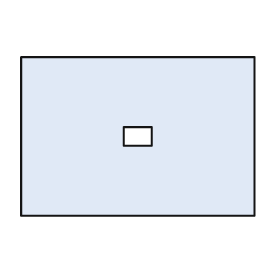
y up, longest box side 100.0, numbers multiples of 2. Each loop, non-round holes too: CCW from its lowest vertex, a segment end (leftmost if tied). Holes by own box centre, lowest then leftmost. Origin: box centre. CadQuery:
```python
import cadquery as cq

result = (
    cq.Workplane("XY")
    .moveTo(-50.0, -34.0)
    .lineTo(50.0, -34.0)
    .lineTo(50.0, 34.0)
    .lineTo(-50.0, 34.0)
    .close()
    .moveTo(-6.0, -4.0)
    .lineTo(6.0, -4.0)
    .lineTo(6.0, 4.0)
    .lineTo(-6.0, 4.0)
    .close()
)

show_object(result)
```